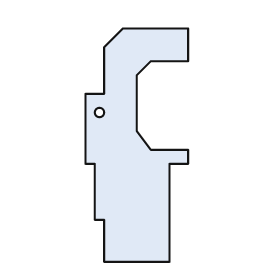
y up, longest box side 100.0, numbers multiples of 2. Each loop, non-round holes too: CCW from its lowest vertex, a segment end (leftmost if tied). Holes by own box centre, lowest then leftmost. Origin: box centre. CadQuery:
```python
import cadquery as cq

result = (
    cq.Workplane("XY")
    .moveTo(-14.0, -50.0)
    .lineTo(14.0, -50.0)
    .lineTo(14.0, -8.0)
    .lineTo(22.0, -8.0)
    .lineTo(22.0, -2.0)
    .lineTo(6.0, -2.0)
    .lineTo(0.0, 6.0)
    .lineTo(0.0, 30.0)
    .lineTo(6.0, 36.0)
    .lineTo(22.0, 36.0)
    .lineTo(22.0, 50.0)
    .lineTo(-6.0, 50.0)
    .lineTo(-14.0, 42.0)
    .lineTo(-14.0, 22.0)
    .lineTo(-22.0, 22.0)
    .lineTo(-22.0, -8.0)
    .lineTo(-18.0, -8.0)
    .lineTo(-18.0, -32.0)
    .lineTo(-14.0, -32.0)
    .close()
    .moveTo(-16.0, 14.0)
    .circle(2.0)
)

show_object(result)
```